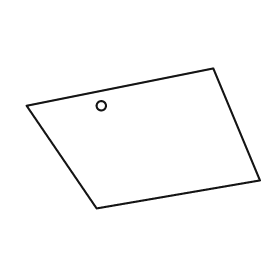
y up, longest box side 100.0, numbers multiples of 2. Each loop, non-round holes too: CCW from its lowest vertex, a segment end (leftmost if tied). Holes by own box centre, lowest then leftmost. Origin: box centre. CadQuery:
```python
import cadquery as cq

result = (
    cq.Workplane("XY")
    .moveTo(-20.0, -30.0)
    .lineTo(50.0, -18.0)
    .lineTo(30.0, 30.0)
    .lineTo(-50.0, 14.0)
    .close()
    .moveTo(-18.0, 14.0)
    .circle(2.0)
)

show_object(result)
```